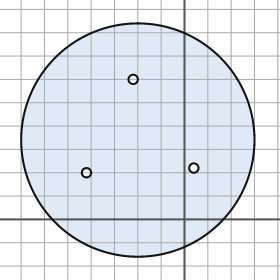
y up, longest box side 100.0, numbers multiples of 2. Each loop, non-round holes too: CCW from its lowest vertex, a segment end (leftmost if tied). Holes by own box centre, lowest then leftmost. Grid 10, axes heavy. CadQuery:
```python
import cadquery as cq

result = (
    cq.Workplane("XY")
    .moveTo(-20.0, 34.0)
    .circle(50.0)
    .moveTo(-42.0, 20.0)
    .circle(2.0)
    .moveTo(4.0, 22.0)
    .circle(2.0)
    .moveTo(-22.0, 60.0)
    .circle(2.0)
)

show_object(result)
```